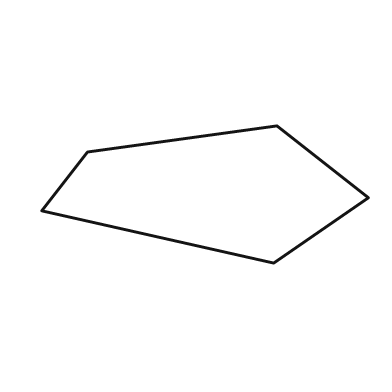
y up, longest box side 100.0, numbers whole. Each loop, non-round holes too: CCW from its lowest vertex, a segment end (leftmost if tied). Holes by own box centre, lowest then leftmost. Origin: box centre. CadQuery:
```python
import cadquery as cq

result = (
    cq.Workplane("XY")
    .moveTo(21.0, -21.0)
    .lineTo(50.0, -1.0)
    .lineTo(22.0, 21.0)
    .lineTo(-36.0, 13.0)
    .lineTo(-50.0, -5.0)
    .close()
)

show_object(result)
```